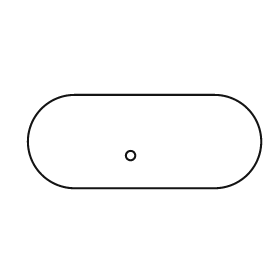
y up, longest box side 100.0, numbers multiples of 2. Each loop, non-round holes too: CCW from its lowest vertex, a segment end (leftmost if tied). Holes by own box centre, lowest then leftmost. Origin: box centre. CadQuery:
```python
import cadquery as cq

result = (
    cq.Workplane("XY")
    .moveTo(-30.0, -20.0)
    .lineTo(30.0, -20.0)
    .threePointArc((50.0, 0.0), (30.0, 20.0))
    .lineTo(-30.0, 20.0)
    .threePointArc((-50.0, 0.0), (-30.0, -20.0))
    .close()
    .moveTo(-6.0, -6.0)
    .circle(2.0)
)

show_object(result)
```